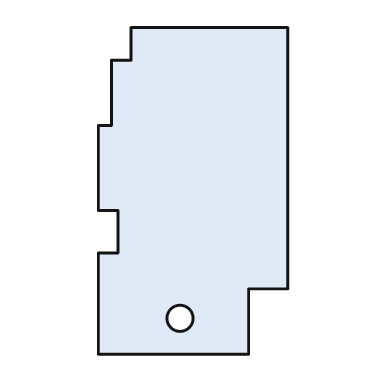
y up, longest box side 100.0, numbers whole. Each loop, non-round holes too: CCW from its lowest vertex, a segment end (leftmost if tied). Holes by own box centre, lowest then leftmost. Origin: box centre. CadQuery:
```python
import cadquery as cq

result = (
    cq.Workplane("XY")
    .moveTo(-29.0, -50.0)
    .lineTo(17.0, -50.0)
    .lineTo(17.0, -30.0)
    .lineTo(29.0, -30.0)
    .lineTo(29.0, 50.0)
    .lineTo(-19.0, 50.0)
    .lineTo(-19.0, 40.0)
    .lineTo(-25.0, 40.0)
    .lineTo(-25.0, 20.0)
    .lineTo(-29.0, 20.0)
    .lineTo(-29.0, -6.0)
    .lineTo(-23.0, -6.0)
    .lineTo(-23.0, -19.0)
    .lineTo(-29.0, -19.0)
    .close()
    .moveTo(-4.0, -39.0)
    .circle(4.0)
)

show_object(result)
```